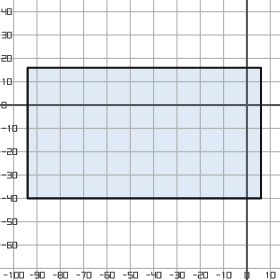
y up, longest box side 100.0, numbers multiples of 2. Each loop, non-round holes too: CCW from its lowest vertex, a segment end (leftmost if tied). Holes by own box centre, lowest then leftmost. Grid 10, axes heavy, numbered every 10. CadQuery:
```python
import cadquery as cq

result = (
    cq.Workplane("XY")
    .moveTo(-94.0, -40.0)
    .lineTo(6.0, -40.0)
    .lineTo(6.0, 16.0)
    .lineTo(-94.0, 16.0)
    .close()
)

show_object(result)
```